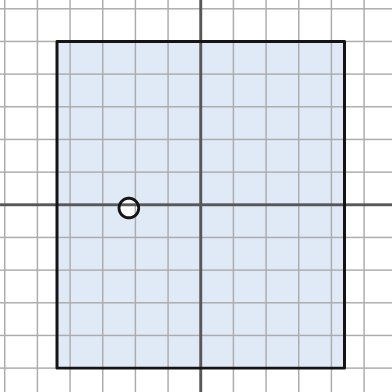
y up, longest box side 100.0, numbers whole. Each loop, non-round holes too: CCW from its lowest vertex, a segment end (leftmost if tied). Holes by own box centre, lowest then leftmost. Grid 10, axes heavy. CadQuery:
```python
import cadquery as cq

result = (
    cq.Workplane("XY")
    .moveTo(-44.0, -50.0)
    .lineTo(44.0, -50.0)
    .lineTo(44.0, 50.0)
    .lineTo(-44.0, 50.0)
    .close()
    .moveTo(-22.0, -1.0)
    .circle(3.0)
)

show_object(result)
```